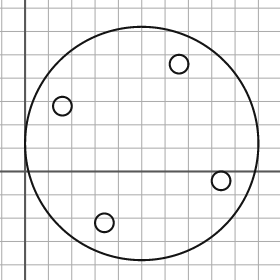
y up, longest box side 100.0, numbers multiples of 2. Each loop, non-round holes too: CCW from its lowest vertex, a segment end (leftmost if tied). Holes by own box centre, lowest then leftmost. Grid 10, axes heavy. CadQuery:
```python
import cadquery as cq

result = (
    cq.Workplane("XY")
    .moveTo(50.0, 12.0)
    .circle(50.0)
    .moveTo(34.0, -22.0)
    .circle(4.0)
    .moveTo(84.0, -4.0)
    .circle(4.0)
    .moveTo(16.0, 28.0)
    .circle(4.0)
    .moveTo(66.0, 46.0)
    .circle(4.0)
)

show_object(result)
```